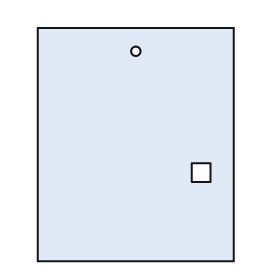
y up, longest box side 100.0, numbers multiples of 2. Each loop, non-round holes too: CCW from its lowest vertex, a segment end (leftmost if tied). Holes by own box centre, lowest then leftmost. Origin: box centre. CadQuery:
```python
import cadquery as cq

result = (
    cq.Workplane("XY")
    .moveTo(-42.0, -50.0)
    .lineTo(42.0, -50.0)
    .lineTo(42.0, 50.0)
    .lineTo(-42.0, 50.0)
    .close()
    .moveTo(24.0, -16.0)
    .lineTo(32.0, -16.0)
    .lineTo(32.0, -8.0)
    .lineTo(24.0, -8.0)
    .close()
    .moveTo(0.0, 40.0)
    .circle(2.0)
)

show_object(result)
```